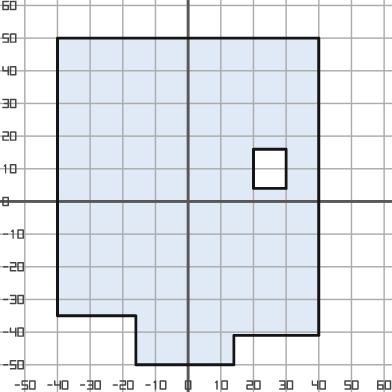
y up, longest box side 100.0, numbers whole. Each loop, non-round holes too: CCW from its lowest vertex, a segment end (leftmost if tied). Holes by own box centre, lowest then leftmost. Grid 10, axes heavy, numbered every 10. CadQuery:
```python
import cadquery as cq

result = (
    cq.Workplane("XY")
    .moveTo(-16.0, -50.0)
    .lineTo(14.0, -50.0)
    .lineTo(14.0, -41.0)
    .lineTo(40.0, -41.0)
    .lineTo(40.0, 50.0)
    .lineTo(-40.0, 50.0)
    .lineTo(-40.0, -35.0)
    .lineTo(-16.0, -35.0)
    .close()
    .moveTo(20.0, 4.0)
    .lineTo(30.0, 4.0)
    .lineTo(30.0, 16.0)
    .lineTo(20.0, 16.0)
    .close()
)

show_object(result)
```